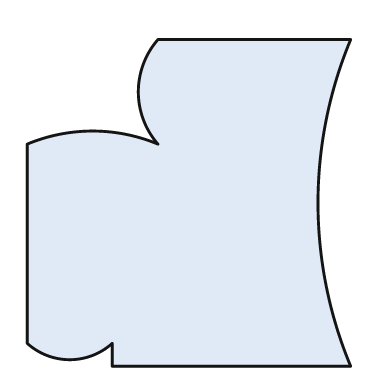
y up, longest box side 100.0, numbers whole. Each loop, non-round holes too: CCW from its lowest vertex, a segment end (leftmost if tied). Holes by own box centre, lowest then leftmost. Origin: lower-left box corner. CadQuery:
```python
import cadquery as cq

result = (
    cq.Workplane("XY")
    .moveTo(26.0, 0.0)
    .lineTo(99.0, 0.0)
    .threePointArc((89.0, 50.0), (99.0, 100.0))
    .lineTo(40.0, 100.0)
    .threePointArc((34.0, 84.0), (40.0, 68.0))
    .threePointArc((20.0, 72.0), (0.0, 68.0))
    .lineTo(0.0, 7.0)
    .threePointArc((13.0, 2.0), (26.0, 7.0))
    .close()
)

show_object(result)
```